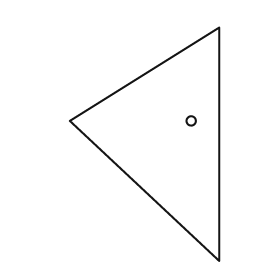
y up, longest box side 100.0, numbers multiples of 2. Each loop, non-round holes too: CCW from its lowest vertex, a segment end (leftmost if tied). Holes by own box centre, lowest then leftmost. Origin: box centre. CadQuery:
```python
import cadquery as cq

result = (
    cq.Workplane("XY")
    .moveTo(32.0, -50.0)
    .lineTo(32.0, 50.0)
    .lineTo(-32.0, 10.0)
    .close()
    .moveTo(20.0, 10.0)
    .circle(2.0)
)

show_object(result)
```